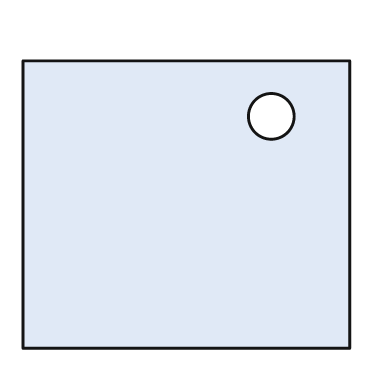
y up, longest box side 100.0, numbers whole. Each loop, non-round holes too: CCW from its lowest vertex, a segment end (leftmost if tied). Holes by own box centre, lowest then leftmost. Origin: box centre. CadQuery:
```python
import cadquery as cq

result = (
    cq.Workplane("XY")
    .moveTo(-50.0, -44.0)
    .lineTo(50.0, -44.0)
    .lineTo(50.0, 44.0)
    .lineTo(-50.0, 44.0)
    .close()
    .moveTo(26.0, 27.0)
    .circle(7.0)
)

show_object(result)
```